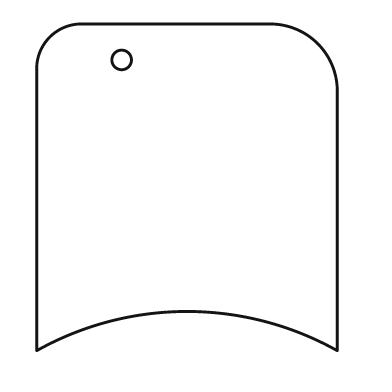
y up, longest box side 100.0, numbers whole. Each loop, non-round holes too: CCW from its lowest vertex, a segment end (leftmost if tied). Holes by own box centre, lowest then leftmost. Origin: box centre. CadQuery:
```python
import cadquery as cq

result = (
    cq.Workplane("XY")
    .moveTo(-46.0, -50.0)
    .threePointArc((0.0, -38.0), (46.0, -50.0))
    .lineTo(46.0, 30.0)
    .threePointArc((40.0, 44.0), (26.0, 50.0))
    .lineTo(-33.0, 50.0)
    .threePointArc((-42.0, 46.0), (-46.0, 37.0))
    .close()
    .moveTo(-20.0, 39.0)
    .circle(3.0)
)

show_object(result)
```